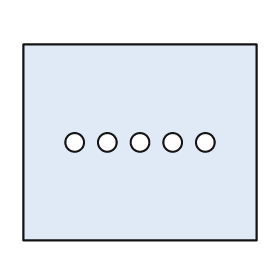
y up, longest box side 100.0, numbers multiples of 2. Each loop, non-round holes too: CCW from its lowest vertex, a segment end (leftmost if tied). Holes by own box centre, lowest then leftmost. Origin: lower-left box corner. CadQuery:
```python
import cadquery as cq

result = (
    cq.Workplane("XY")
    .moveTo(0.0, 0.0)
    .lineTo(100.0, 0.0)
    .lineTo(100.0, 84.0)
    .lineTo(0.0, 84.0)
    .close()
    .moveTo(22.0, 42.0)
    .circle(4.0)
    .moveTo(36.0, 42.0)
    .circle(4.0)
    .moveTo(50.0, 42.0)
    .circle(4.0)
    .moveTo(64.0, 42.0)
    .circle(4.0)
    .moveTo(78.0, 42.0)
    .circle(4.0)
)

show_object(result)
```